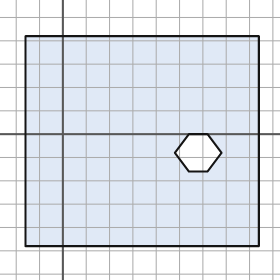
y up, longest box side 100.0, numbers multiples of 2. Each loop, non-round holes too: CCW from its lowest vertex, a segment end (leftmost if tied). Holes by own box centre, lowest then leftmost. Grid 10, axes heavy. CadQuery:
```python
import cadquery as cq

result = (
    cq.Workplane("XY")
    .moveTo(-16.0, -48.0)
    .lineTo(84.0, -48.0)
    .lineTo(84.0, 42.0)
    .lineTo(-16.0, 42.0)
    .close()
    .moveTo(54.0, -16.0)
    .lineTo(62.0, -16.0)
    .lineTo(68.0, -8.0)
    .lineTo(62.0, 0.0)
    .lineTo(54.0, 0.0)
    .lineTo(48.0, -8.0)
    .close()
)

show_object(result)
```